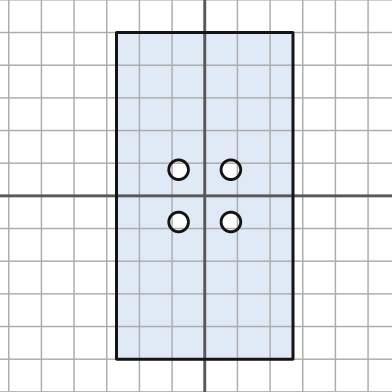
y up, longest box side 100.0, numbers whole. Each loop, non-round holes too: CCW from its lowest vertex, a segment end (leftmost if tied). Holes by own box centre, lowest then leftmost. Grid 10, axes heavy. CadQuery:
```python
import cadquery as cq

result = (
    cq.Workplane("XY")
    .moveTo(-27.0, -50.0)
    .lineTo(27.0, -50.0)
    .lineTo(27.0, 50.0)
    .lineTo(-27.0, 50.0)
    .close()
    .moveTo(-8.0, -8.0)
    .circle(3.0)
    .moveTo(8.0, -8.0)
    .circle(3.0)
    .moveTo(-8.0, 8.0)
    .circle(3.0)
    .moveTo(8.0, 8.0)
    .circle(3.0)
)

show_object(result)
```